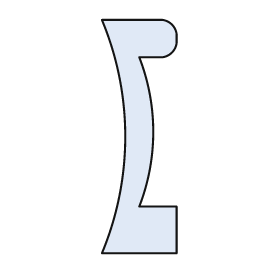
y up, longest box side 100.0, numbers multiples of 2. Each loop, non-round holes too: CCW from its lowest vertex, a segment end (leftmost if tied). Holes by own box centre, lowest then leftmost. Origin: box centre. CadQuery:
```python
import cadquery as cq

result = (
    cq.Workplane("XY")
    .moveTo(-16.0, -50.0)
    .lineTo(16.0, -50.0)
    .lineTo(16.0, -30.0)
    .lineTo(0.0, -30.0)
    .threePointArc((6.0, 2.0), (0.0, 34.0))
    .lineTo(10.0, 34.0)
    .threePointArc((14.0, 36.0), (16.0, 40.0))
    .lineTo(16.0, 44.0)
    .threePointArc((14.0, 48.0), (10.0, 50.0))
    .lineTo(-16.0, 50.0)
    .threePointArc((-6.0, 0.0), (-16.0, -50.0))
    .close()
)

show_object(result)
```